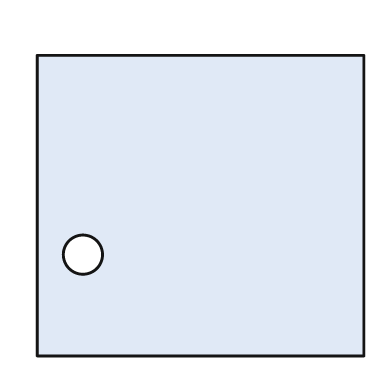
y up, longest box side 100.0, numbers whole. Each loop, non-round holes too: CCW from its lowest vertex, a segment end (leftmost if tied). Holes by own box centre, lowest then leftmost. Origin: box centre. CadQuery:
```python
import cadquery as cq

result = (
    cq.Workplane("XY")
    .moveTo(-50.0, -46.0)
    .lineTo(50.0, -46.0)
    .lineTo(50.0, 46.0)
    .lineTo(-50.0, 46.0)
    .close()
    .moveTo(-36.0, -15.0)
    .circle(6.0)
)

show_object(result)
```